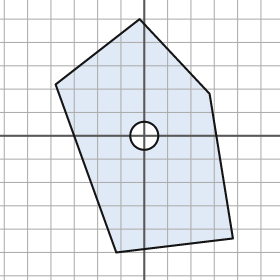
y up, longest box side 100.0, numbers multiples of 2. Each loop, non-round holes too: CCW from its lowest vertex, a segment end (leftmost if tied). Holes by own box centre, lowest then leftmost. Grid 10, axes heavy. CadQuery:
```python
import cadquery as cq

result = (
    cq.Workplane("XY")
    .moveTo(-12.0, -50.0)
    .lineTo(38.0, -44.0)
    .lineTo(28.0, 18.0)
    .lineTo(-2.0, 50.0)
    .lineTo(-38.0, 22.0)
    .close()
    .moveTo(0.0, 0.0)
    .circle(6.0)
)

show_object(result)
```